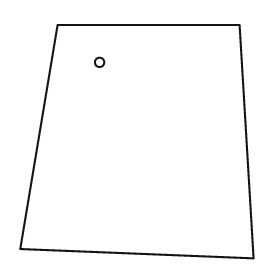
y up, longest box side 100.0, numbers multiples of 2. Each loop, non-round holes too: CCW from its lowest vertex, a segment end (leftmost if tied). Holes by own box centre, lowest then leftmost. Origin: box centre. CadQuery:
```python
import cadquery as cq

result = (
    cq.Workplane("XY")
    .moveTo(50.0, -50.0)
    .lineTo(44.0, 50.0)
    .lineTo(-34.0, 50.0)
    .lineTo(-50.0, -46.0)
    .close()
    .moveTo(-16.0, 34.0)
    .circle(2.0)
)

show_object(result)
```